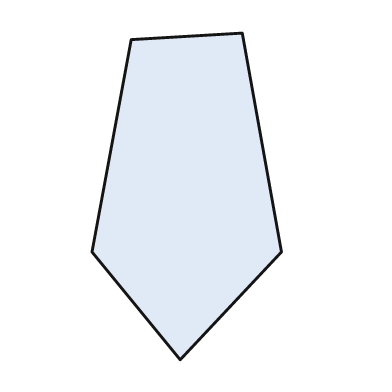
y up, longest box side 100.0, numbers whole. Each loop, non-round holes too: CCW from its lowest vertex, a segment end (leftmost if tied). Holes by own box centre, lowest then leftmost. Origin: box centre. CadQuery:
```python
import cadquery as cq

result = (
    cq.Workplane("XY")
    .moveTo(-2.0, -50.0)
    .lineTo(29.0, -17.0)
    .lineTo(17.0, 50.0)
    .lineTo(-17.0, 48.0)
    .lineTo(-29.0, -17.0)
    .close()
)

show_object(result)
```